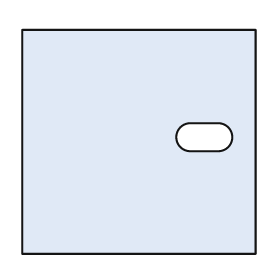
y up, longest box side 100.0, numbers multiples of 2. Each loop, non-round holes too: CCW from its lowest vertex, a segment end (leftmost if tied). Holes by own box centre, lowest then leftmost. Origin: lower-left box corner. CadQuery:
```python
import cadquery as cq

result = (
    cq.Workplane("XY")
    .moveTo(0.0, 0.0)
    .lineTo(100.0, 0.0)
    .lineTo(100.0, 96.0)
    .lineTo(0.0, 96.0)
    .close()
    .moveTo(72.0, 44.0)
    .lineTo(84.0, 44.0)
    .threePointArc((90.0, 50.0), (84.0, 56.0))
    .lineTo(72.0, 56.0)
    .threePointArc((66.0, 50.0), (72.0, 44.0))
    .close()
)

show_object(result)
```